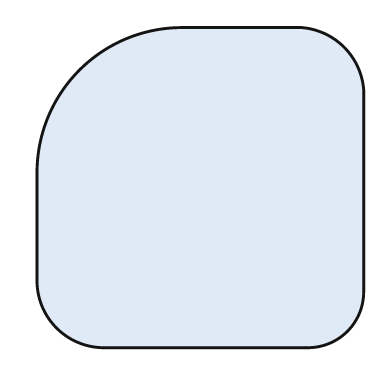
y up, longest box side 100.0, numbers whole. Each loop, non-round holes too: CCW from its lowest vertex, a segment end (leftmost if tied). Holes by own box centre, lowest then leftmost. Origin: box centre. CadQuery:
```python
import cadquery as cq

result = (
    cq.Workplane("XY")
    .moveTo(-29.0, -49.0)
    .lineTo(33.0, -49.0)
    .threePointArc((45.0, -44.0), (50.0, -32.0))
    .lineTo(50.0, 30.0)
    .threePointArc((44.0, 43.0), (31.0, 49.0))
    .lineTo(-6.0, 49.0)
    .threePointArc((-37.0, 36.0), (-50.0, 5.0))
    .lineTo(-50.0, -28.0)
    .threePointArc((-44.0, -43.0), (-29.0, -49.0))
    .close()
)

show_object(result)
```